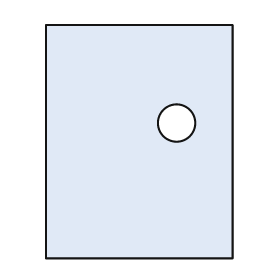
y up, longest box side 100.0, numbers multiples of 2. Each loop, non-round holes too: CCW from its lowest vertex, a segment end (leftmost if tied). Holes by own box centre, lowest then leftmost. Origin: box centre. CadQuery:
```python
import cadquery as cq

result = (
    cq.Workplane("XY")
    .moveTo(-40.0, -50.0)
    .lineTo(40.0, -50.0)
    .lineTo(40.0, 50.0)
    .lineTo(-40.0, 50.0)
    .close()
    .moveTo(16.0, 8.0)
    .circle(8.0)
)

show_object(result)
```